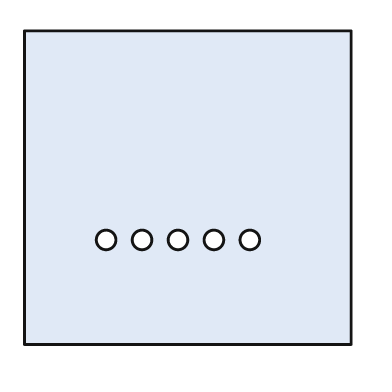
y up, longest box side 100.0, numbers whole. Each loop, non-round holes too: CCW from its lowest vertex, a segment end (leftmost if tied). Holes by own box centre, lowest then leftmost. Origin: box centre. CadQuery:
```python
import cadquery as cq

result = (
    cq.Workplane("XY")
    .moveTo(-50.0, -48.0)
    .lineTo(50.0, -48.0)
    .lineTo(50.0, 48.0)
    .lineTo(-50.0, 48.0)
    .close()
    .moveTo(-25.0, -16.0)
    .circle(3.0)
    .moveTo(-14.0, -16.0)
    .circle(3.0)
    .moveTo(-3.0, -16.0)
    .circle(3.0)
    .moveTo(8.0, -16.0)
    .circle(3.0)
    .moveTo(19.0, -16.0)
    .circle(3.0)
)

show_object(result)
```